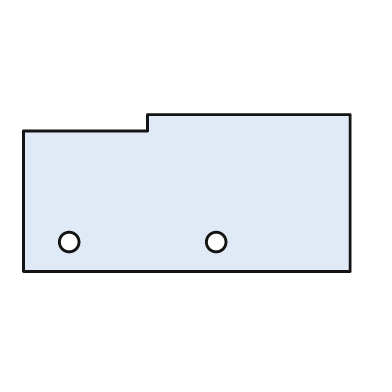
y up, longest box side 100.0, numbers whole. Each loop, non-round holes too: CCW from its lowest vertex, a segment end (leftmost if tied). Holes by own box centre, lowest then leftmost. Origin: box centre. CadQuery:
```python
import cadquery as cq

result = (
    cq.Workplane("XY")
    .moveTo(-50.0, -24.0)
    .lineTo(50.0, -24.0)
    .lineTo(50.0, 24.0)
    .lineTo(-12.0, 24.0)
    .lineTo(-12.0, 19.0)
    .lineTo(-50.0, 19.0)
    .close()
    .moveTo(-36.0, -15.0)
    .circle(3.0)
    .moveTo(9.0, -15.0)
    .circle(3.0)
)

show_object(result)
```